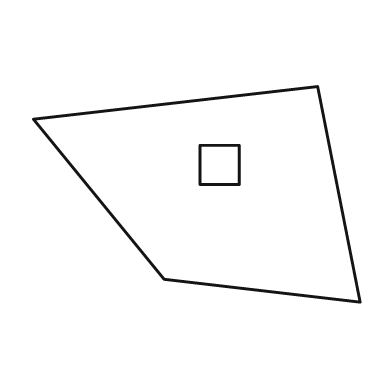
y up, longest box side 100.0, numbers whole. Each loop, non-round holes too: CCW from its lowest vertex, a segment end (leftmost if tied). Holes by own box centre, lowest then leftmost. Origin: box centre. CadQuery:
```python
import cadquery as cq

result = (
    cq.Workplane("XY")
    .moveTo(50.0, -33.0)
    .lineTo(37.0, 33.0)
    .lineTo(-50.0, 23.0)
    .lineTo(-10.0, -26.0)
    .close()
    .moveTo(1.0, 3.0)
    .lineTo(13.0, 3.0)
    .lineTo(13.0, 15.0)
    .lineTo(1.0, 15.0)
    .close()
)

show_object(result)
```